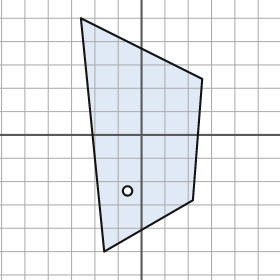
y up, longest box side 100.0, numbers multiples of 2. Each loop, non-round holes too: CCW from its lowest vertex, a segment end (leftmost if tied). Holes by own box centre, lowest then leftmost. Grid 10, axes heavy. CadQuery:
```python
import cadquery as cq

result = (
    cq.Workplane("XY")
    .moveTo(-16.0, -50.0)
    .lineTo(22.0, -28.0)
    .lineTo(26.0, 24.0)
    .lineTo(-26.0, 50.0)
    .close()
    .moveTo(-6.0, -24.0)
    .circle(2.0)
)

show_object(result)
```